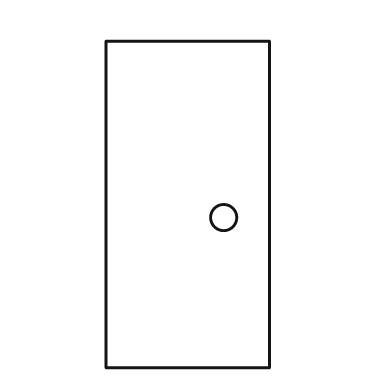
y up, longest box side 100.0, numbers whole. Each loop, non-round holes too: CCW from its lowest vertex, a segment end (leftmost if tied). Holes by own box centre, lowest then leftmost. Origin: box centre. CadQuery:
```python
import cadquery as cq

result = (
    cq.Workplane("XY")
    .moveTo(-25.0, -50.0)
    .lineTo(25.0, -50.0)
    .lineTo(25.0, 50.0)
    .lineTo(-25.0, 50.0)
    .close()
    .moveTo(11.0, -4.0)
    .circle(4.0)
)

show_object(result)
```